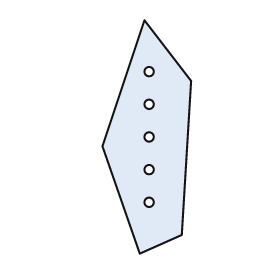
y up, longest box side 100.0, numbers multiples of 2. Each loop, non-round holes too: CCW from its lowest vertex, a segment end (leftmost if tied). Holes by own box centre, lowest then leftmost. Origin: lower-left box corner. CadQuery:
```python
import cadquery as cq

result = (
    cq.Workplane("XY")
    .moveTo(16.0, 0.0)
    .lineTo(34.0, 8.0)
    .lineTo(38.0, 74.0)
    .lineTo(18.0, 100.0)
    .lineTo(0.0, 46.0)
    .close()
    .moveTo(20.0, 22.0)
    .circle(2.0)
    .moveTo(20.0, 36.0)
    .circle(2.0)
    .moveTo(20.0, 50.0)
    .circle(2.0)
    .moveTo(20.0, 64.0)
    .circle(2.0)
    .moveTo(20.0, 78.0)
    .circle(2.0)
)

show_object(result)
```